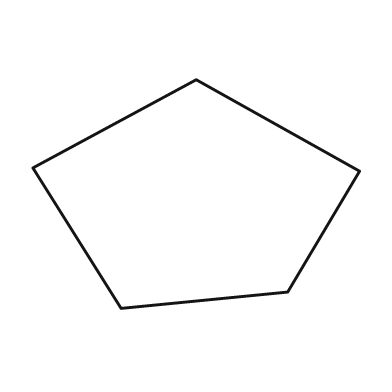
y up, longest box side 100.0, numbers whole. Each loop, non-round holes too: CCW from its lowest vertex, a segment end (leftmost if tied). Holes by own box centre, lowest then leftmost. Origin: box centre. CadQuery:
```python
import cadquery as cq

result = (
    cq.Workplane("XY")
    .moveTo(-23.0, -35.0)
    .lineTo(28.0, -30.0)
    .lineTo(50.0, 7.0)
    .lineTo(0.0, 35.0)
    .lineTo(-50.0, 8.0)
    .close()
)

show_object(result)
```